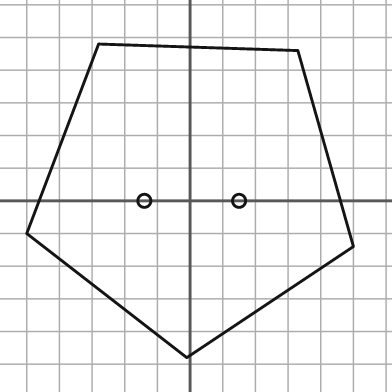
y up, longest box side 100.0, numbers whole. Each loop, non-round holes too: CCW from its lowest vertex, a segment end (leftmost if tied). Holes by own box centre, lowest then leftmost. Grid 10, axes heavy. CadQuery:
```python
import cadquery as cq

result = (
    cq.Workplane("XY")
    .moveTo(-1.0, -48.0)
    .lineTo(50.0, -14.0)
    .lineTo(33.0, 46.0)
    .lineTo(-28.0, 48.0)
    .lineTo(-50.0, -10.0)
    .close()
    .moveTo(-14.0, 0.0)
    .circle(2.0)
    .moveTo(15.0, 0.0)
    .circle(2.0)
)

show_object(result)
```